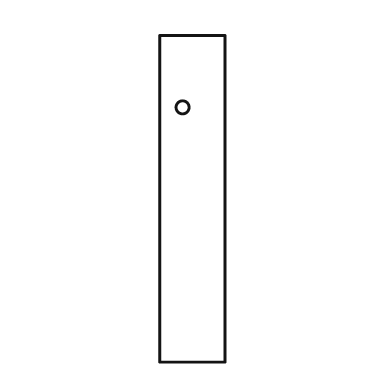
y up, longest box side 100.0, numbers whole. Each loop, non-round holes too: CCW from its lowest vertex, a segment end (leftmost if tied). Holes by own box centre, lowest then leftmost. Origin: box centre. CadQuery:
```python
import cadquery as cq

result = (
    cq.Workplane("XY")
    .moveTo(-10.0, -50.0)
    .lineTo(10.0, -50.0)
    .lineTo(10.0, 50.0)
    .lineTo(-10.0, 50.0)
    .close()
    .moveTo(-3.0, 28.0)
    .circle(2.0)
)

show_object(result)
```